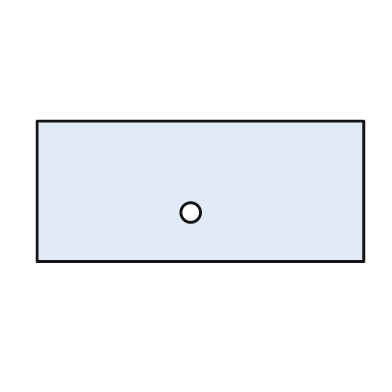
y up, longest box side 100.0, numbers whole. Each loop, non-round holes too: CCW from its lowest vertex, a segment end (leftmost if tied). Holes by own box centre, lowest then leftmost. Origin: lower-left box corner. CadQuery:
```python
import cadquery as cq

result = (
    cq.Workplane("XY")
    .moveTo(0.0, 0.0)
    .lineTo(100.0, 0.0)
    .lineTo(100.0, 43.0)
    .lineTo(0.0, 43.0)
    .close()
    .moveTo(47.0, 15.0)
    .circle(3.0)
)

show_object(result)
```